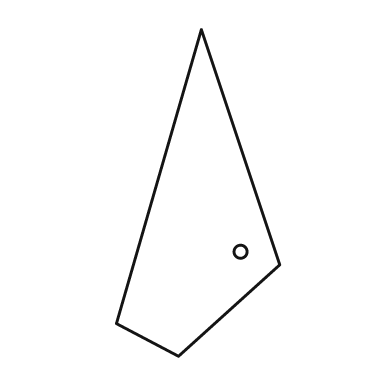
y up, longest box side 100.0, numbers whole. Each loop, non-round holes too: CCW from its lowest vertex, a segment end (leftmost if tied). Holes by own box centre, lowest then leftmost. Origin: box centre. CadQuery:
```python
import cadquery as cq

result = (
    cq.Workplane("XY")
    .moveTo(-6.0, -50.0)
    .lineTo(25.0, -22.0)
    .lineTo(1.0, 50.0)
    .lineTo(-25.0, -40.0)
    .close()
    .moveTo(13.0, -18.0)
    .circle(2.0)
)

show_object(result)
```